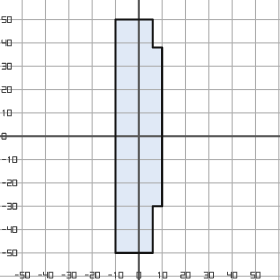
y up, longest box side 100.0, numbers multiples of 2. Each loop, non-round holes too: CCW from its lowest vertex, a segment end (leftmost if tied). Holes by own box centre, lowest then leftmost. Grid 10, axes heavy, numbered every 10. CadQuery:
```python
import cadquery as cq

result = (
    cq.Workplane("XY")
    .moveTo(-10.0, -50.0)
    .lineTo(6.0, -50.0)
    .lineTo(6.0, -30.0)
    .lineTo(10.0, -30.0)
    .lineTo(10.0, 38.0)
    .lineTo(6.0, 38.0)
    .lineTo(6.0, 50.0)
    .lineTo(-10.0, 50.0)
    .close()
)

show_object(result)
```